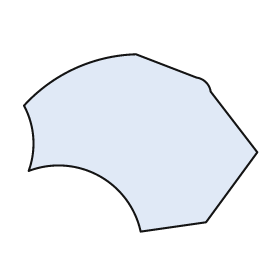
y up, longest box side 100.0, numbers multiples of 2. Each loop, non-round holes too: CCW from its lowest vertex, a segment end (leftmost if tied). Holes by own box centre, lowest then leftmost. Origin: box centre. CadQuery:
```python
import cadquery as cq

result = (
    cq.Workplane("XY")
    .moveTo(0.0, -38.0)
    .lineTo(28.0, -34.0)
    .lineTo(50.0, -4.0)
    .lineTo(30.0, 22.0)
    .threePointArc((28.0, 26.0), (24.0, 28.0))
    .lineTo(-2.0, 38.0)
    .threePointArc((-28.0, 32.0), (-50.0, 16.0))
    .threePointArc((-46.0, 2.0), (-48.0, -12.0))
    .threePointArc((-18.0, -14.0), (0.0, -38.0))
    .close()
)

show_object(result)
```